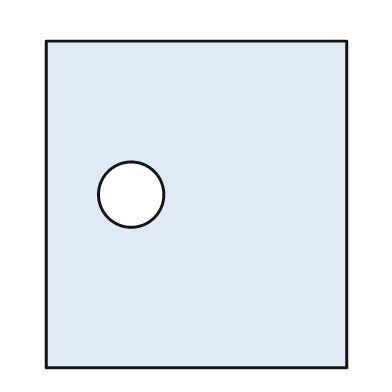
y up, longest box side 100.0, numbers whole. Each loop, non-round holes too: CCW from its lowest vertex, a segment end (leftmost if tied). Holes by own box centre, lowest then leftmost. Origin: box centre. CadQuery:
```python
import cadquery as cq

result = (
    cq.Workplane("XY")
    .moveTo(-46.0, -50.0)
    .lineTo(46.0, -50.0)
    .lineTo(46.0, 50.0)
    .lineTo(-46.0, 50.0)
    .close()
    .moveTo(-20.0, 3.0)
    .circle(10.0)
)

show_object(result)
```